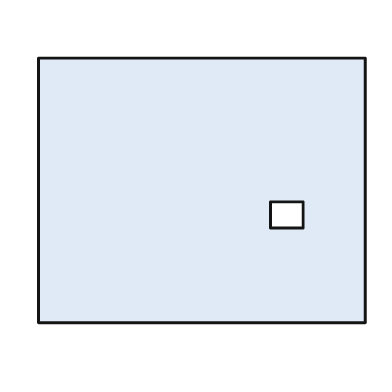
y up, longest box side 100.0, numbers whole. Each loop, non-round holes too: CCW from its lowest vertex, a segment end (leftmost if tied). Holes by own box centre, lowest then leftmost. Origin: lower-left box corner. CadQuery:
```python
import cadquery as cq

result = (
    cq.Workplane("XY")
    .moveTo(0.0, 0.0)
    .lineTo(100.0, 0.0)
    .lineTo(100.0, 81.0)
    .lineTo(0.0, 81.0)
    .close()
    .moveTo(71.0, 29.0)
    .lineTo(81.0, 29.0)
    .lineTo(81.0, 37.0)
    .lineTo(71.0, 37.0)
    .close()
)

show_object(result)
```